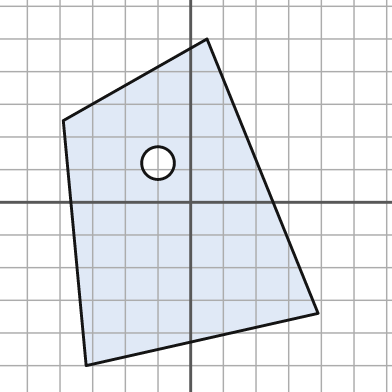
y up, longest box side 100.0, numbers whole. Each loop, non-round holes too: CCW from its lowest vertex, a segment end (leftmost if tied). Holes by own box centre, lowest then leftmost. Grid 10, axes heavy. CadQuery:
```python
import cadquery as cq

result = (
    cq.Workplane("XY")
    .moveTo(-32.0, -50.0)
    .lineTo(39.0, -34.0)
    .lineTo(5.0, 50.0)
    .lineTo(-39.0, 25.0)
    .close()
    .moveTo(-10.0, 12.0)
    .circle(5.0)
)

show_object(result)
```